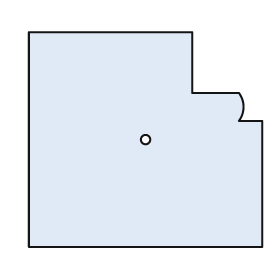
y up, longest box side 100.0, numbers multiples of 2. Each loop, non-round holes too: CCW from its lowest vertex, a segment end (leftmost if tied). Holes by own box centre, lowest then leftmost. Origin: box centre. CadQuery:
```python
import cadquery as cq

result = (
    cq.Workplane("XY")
    .moveTo(-50.0, -46.0)
    .lineTo(50.0, -46.0)
    .lineTo(50.0, 8.0)
    .lineTo(40.0, 8.0)
    .threePointArc((42.0, 14.0), (40.0, 20.0))
    .lineTo(20.0, 20.0)
    .lineTo(20.0, 46.0)
    .lineTo(-50.0, 46.0)
    .close()
    .moveTo(0.0, 0.0)
    .circle(2.0)
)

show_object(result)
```